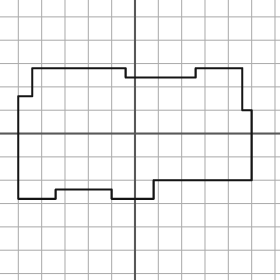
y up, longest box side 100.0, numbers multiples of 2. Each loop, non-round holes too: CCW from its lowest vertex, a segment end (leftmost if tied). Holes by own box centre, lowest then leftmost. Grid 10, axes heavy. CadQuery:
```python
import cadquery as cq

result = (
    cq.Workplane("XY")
    .moveTo(-50.0, -28.0)
    .lineTo(-34.0, -28.0)
    .lineTo(-34.0, -24.0)
    .lineTo(-10.0, -24.0)
    .lineTo(-10.0, -28.0)
    .lineTo(8.0, -28.0)
    .lineTo(8.0, -20.0)
    .lineTo(50.0, -20.0)
    .lineTo(50.0, 10.0)
    .lineTo(46.0, 10.0)
    .lineTo(46.0, 28.0)
    .lineTo(26.0, 28.0)
    .lineTo(26.0, 24.0)
    .lineTo(-4.0, 24.0)
    .lineTo(-4.0, 28.0)
    .lineTo(-44.0, 28.0)
    .lineTo(-44.0, 16.0)
    .lineTo(-50.0, 16.0)
    .close()
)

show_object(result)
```